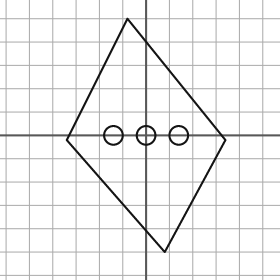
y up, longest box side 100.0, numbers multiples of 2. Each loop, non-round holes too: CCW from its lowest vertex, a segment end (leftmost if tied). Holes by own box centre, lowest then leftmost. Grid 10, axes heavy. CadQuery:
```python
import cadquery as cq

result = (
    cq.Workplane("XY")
    .moveTo(8.0, -50.0)
    .lineTo(34.0, -2.0)
    .lineTo(-8.0, 50.0)
    .lineTo(-34.0, -2.0)
    .close()
    .moveTo(-14.0, 0.0)
    .circle(4.0)
    .moveTo(0.0, 0.0)
    .circle(4.0)
    .moveTo(14.0, 0.0)
    .circle(4.0)
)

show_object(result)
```